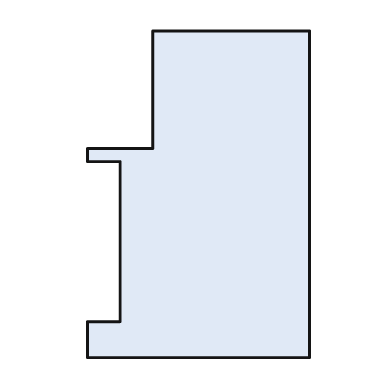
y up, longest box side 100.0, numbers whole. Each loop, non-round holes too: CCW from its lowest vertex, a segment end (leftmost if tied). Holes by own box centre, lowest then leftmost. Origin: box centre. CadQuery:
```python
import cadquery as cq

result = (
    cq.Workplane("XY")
    .moveTo(-34.0, -50.0)
    .lineTo(34.0, -50.0)
    .lineTo(34.0, 50.0)
    .lineTo(-14.0, 50.0)
    .lineTo(-14.0, 14.0)
    .lineTo(-34.0, 14.0)
    .lineTo(-34.0, 10.0)
    .lineTo(-24.0, 10.0)
    .lineTo(-24.0, -39.0)
    .lineTo(-34.0, -39.0)
    .close()
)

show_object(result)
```